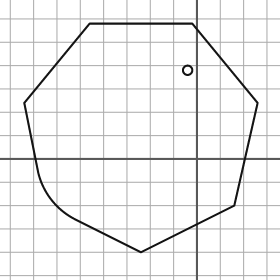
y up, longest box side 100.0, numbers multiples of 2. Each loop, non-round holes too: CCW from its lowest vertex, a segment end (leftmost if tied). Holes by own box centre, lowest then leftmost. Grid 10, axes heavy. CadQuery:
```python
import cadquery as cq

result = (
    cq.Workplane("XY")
    .moveTo(-24.0, -40.0)
    .lineTo(16.0, -20.0)
    .lineTo(26.0, 24.0)
    .lineTo(-2.0, 58.0)
    .lineTo(-46.0, 58.0)
    .lineTo(-74.0, 24.0)
    .lineTo(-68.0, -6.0)
    .threePointArc((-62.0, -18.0), (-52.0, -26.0))
    .close()
    .moveTo(-4.0, 38.0)
    .circle(2.0)
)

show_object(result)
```